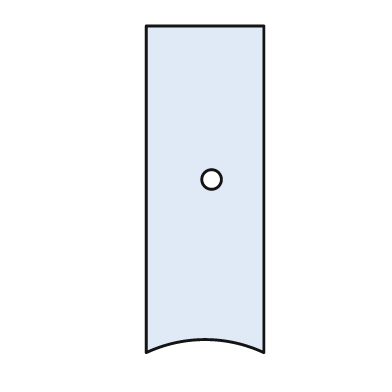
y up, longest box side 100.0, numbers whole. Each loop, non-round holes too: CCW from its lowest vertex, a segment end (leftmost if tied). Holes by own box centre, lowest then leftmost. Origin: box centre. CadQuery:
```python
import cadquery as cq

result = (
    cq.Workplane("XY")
    .moveTo(-18.0, -50.0)
    .threePointArc((0.0, -46.0), (18.0, -50.0))
    .lineTo(18.0, 50.0)
    .lineTo(-18.0, 50.0)
    .close()
    .moveTo(2.0, 3.0)
    .circle(3.0)
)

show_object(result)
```